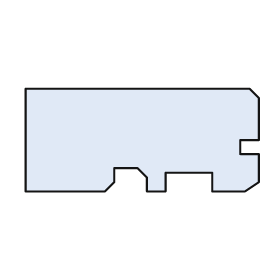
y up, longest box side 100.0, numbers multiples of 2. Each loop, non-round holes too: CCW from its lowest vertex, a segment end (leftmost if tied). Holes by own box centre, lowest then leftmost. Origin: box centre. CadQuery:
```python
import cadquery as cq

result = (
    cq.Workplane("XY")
    .moveTo(-50.0, -22.0)
    .lineTo(-16.0, -22.0)
    .lineTo(-12.0, -18.0)
    .lineTo(-12.0, -12.0)
    .lineTo(-2.0, -12.0)
    .lineTo(2.0, -16.0)
    .lineTo(2.0, -22.0)
    .lineTo(10.0, -22.0)
    .lineTo(10.0, -14.0)
    .lineTo(30.0, -14.0)
    .lineTo(30.0, -22.0)
    .lineTo(44.0, -22.0)
    .lineTo(50.0, -18.0)
    .lineTo(50.0, -6.0)
    .lineTo(42.0, -6.0)
    .lineTo(42.0, 0.0)
    .lineTo(50.0, 0.0)
    .lineTo(50.0, 18.0)
    .lineTo(46.0, 22.0)
    .lineTo(-50.0, 22.0)
    .close()
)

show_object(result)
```